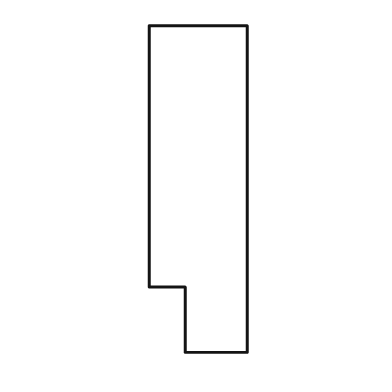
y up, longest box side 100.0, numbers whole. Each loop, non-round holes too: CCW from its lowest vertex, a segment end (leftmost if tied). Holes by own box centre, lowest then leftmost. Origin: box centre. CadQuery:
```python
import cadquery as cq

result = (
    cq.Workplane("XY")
    .moveTo(-4.0, -50.0)
    .lineTo(15.0, -50.0)
    .lineTo(15.0, 50.0)
    .lineTo(-15.0, 50.0)
    .lineTo(-15.0, -30.0)
    .lineTo(-4.0, -30.0)
    .close()
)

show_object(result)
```